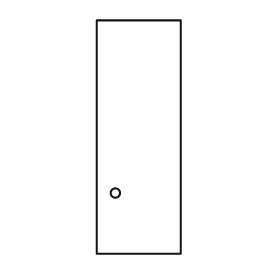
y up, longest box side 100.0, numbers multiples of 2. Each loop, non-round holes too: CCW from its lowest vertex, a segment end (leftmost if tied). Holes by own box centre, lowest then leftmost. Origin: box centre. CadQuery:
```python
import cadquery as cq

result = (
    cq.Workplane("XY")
    .moveTo(-18.0, -50.0)
    .lineTo(18.0, -50.0)
    .lineTo(18.0, 50.0)
    .lineTo(-18.0, 50.0)
    .close()
    .moveTo(-10.0, -24.0)
    .circle(2.0)
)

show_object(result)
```